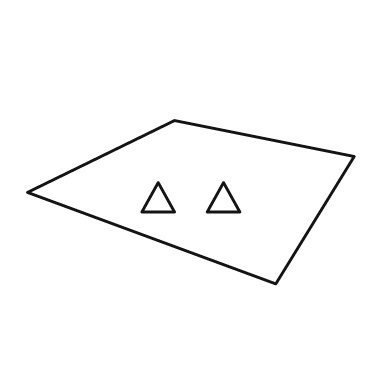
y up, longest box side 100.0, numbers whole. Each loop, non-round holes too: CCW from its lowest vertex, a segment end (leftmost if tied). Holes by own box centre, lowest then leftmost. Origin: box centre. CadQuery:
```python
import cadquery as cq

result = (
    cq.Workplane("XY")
    .moveTo(26.0, -25.0)
    .lineTo(50.0, 14.0)
    .lineTo(-5.0, 25.0)
    .lineTo(-50.0, 3.0)
    .close()
    .moveTo(-15.0, -3.0)
    .lineTo(-5.0, -3.0)
    .lineTo(-10.0, 6.0)
    .close()
    .moveTo(5.0, -3.0)
    .lineTo(15.0, -3.0)
    .lineTo(10.0, 6.0)
    .close()
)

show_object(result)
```